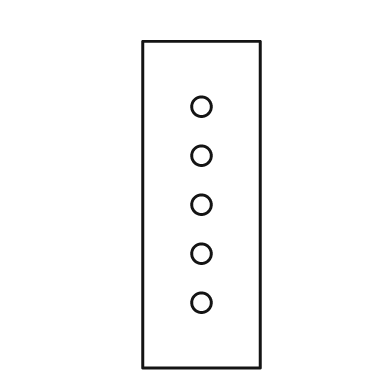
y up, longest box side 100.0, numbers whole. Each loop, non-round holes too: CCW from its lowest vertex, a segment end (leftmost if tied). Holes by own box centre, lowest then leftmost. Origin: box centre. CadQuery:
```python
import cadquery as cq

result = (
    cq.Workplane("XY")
    .moveTo(-18.0, -50.0)
    .lineTo(18.0, -50.0)
    .lineTo(18.0, 50.0)
    .lineTo(-18.0, 50.0)
    .close()
    .moveTo(0.0, -30.0)
    .circle(3.0)
    .moveTo(0.0, -15.0)
    .circle(3.0)
    .moveTo(0.0, 0.0)
    .circle(3.0)
    .moveTo(0.0, 15.0)
    .circle(3.0)
    .moveTo(0.0, 30.0)
    .circle(3.0)
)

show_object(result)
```